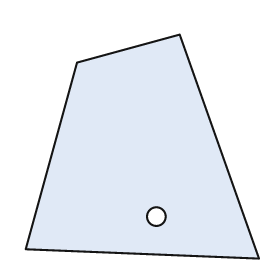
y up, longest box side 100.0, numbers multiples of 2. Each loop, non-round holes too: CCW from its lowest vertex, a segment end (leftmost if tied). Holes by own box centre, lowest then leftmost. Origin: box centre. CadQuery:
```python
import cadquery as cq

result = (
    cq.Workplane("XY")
    .moveTo(50.0, -48.0)
    .lineTo(16.0, 48.0)
    .lineTo(-28.0, 36.0)
    .lineTo(-50.0, -44.0)
    .close()
    .moveTo(6.0, -30.0)
    .circle(4.0)
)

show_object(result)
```